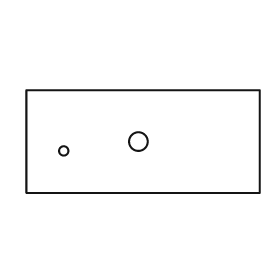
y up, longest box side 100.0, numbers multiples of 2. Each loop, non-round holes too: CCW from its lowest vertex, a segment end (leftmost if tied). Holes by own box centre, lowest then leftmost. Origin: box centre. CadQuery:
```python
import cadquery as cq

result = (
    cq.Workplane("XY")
    .moveTo(-50.0, -22.0)
    .lineTo(50.0, -22.0)
    .lineTo(50.0, 22.0)
    .lineTo(-50.0, 22.0)
    .close()
    .moveTo(-34.0, -4.0)
    .circle(2.0)
    .moveTo(-2.0, 0.0)
    .circle(4.0)
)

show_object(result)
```